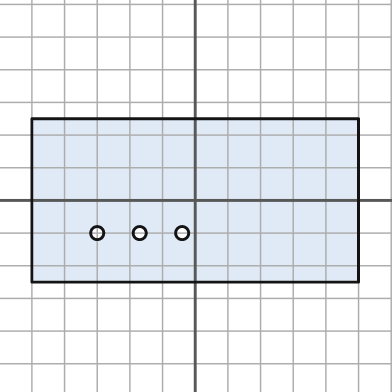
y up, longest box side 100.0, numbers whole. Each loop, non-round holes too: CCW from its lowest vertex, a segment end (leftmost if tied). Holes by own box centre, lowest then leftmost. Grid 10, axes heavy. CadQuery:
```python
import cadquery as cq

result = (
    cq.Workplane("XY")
    .moveTo(-50.0, -25.0)
    .lineTo(50.0, -25.0)
    .lineTo(50.0, 25.0)
    .lineTo(-50.0, 25.0)
    .close()
    .moveTo(-30.0, -10.0)
    .circle(2.0)
    .moveTo(-17.0, -10.0)
    .circle(2.0)
    .moveTo(-4.0, -10.0)
    .circle(2.0)
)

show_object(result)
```